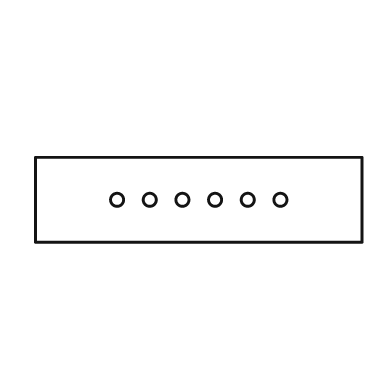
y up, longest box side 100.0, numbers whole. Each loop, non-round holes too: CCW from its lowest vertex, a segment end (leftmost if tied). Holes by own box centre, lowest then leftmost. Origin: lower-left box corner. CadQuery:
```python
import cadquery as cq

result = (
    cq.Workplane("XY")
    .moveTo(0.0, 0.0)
    .lineTo(100.0, 0.0)
    .lineTo(100.0, 26.0)
    .lineTo(0.0, 26.0)
    .close()
    .moveTo(25.0, 13.0)
    .circle(2.0)
    .moveTo(35.0, 13.0)
    .circle(2.0)
    .moveTo(45.0, 13.0)
    .circle(2.0)
    .moveTo(55.0, 13.0)
    .circle(2.0)
    .moveTo(65.0, 13.0)
    .circle(2.0)
    .moveTo(75.0, 13.0)
    .circle(2.0)
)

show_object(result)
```